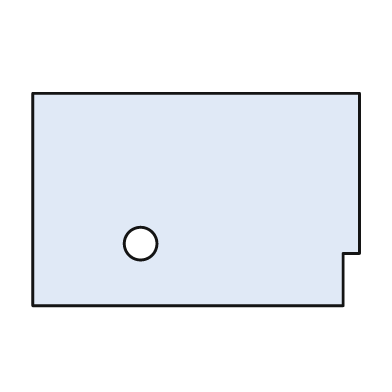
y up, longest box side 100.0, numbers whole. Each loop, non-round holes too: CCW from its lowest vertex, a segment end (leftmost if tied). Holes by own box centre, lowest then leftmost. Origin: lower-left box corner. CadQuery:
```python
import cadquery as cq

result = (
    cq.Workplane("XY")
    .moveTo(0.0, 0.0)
    .lineTo(95.0, 0.0)
    .lineTo(95.0, 16.0)
    .lineTo(100.0, 16.0)
    .lineTo(100.0, 65.0)
    .lineTo(0.0, 65.0)
    .close()
    .moveTo(33.0, 19.0)
    .circle(5.0)
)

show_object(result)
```